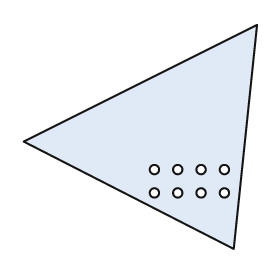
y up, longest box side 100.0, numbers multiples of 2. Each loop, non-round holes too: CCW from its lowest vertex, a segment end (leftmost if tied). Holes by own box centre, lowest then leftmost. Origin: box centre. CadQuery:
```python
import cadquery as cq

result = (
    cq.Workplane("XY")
    .moveTo(40.0, -48.0)
    .lineTo(50.0, 48.0)
    .lineTo(-50.0, -2.0)
    .close()
    .moveTo(6.0, -24.0)
    .circle(2.0)
    .moveTo(16.0, -24.0)
    .circle(2.0)
    .moveTo(26.0, -24.0)
    .circle(2.0)
    .moveTo(36.0, -24.0)
    .circle(2.0)
    .moveTo(6.0, -14.0)
    .circle(2.0)
    .moveTo(16.0, -14.0)
    .circle(2.0)
    .moveTo(26.0, -14.0)
    .circle(2.0)
    .moveTo(36.0, -14.0)
    .circle(2.0)
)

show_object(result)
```